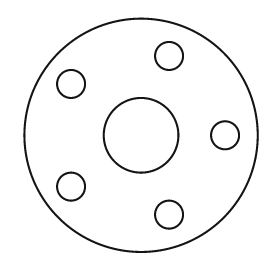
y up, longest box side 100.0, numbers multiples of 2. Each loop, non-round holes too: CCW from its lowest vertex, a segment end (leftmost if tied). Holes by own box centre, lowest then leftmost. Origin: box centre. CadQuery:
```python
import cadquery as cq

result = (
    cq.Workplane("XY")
    .moveTo(0.0, 0.0)
    .circle(50.0)
    .moveTo(12.0, -34.0)
    .circle(6.0)
    .moveTo(-30.0, -22.0)
    .circle(6.0)
    .moveTo(0.0, 0.0)
    .circle(16.0)
    .moveTo(36.0, 0.0)
    .circle(6.0)
    .moveTo(-30.0, 22.0)
    .circle(6.0)
    .moveTo(12.0, 34.0)
    .circle(6.0)
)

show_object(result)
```